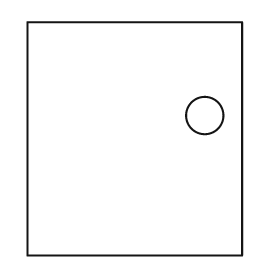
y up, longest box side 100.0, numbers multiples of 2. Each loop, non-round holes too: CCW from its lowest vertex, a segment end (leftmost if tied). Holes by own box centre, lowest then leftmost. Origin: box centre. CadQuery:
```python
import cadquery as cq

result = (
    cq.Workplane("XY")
    .moveTo(-46.0, -50.0)
    .lineTo(46.0, -50.0)
    .lineTo(46.0, 50.0)
    .lineTo(-46.0, 50.0)
    .close()
    .moveTo(30.0, 10.0)
    .circle(8.0)
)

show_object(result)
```